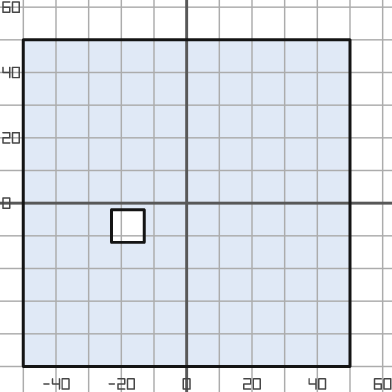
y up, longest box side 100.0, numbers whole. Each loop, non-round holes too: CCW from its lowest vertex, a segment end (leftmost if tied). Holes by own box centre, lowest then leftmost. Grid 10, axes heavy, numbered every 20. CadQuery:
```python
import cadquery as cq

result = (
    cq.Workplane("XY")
    .moveTo(-50.0, -50.0)
    .lineTo(50.0, -50.0)
    .lineTo(50.0, 50.0)
    .lineTo(-50.0, 50.0)
    .close()
    .moveTo(-23.0, -12.0)
    .lineTo(-13.0, -12.0)
    .lineTo(-13.0, -2.0)
    .lineTo(-23.0, -2.0)
    .close()
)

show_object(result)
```